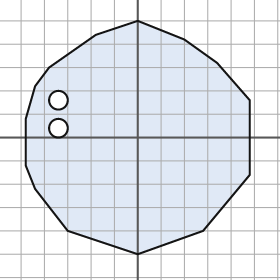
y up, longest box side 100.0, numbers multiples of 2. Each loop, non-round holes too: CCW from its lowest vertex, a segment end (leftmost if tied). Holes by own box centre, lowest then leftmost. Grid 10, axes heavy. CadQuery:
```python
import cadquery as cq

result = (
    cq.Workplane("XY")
    .moveTo(0.0, -50.0)
    .lineTo(28.0, -40.0)
    .lineTo(48.0, -16.0)
    .lineTo(48.0, 16.0)
    .lineTo(34.0, 32.0)
    .lineTo(20.0, 42.0)
    .lineTo(0.0, 50.0)
    .lineTo(-18.0, 44.0)
    .lineTo(-38.0, 30.0)
    .lineTo(-44.0, 22.0)
    .lineTo(-48.0, 8.0)
    .lineTo(-48.0, -12.0)
    .lineTo(-44.0, -22.0)
    .lineTo(-30.0, -40.0)
    .close()
    .moveTo(-34.0, 4.0)
    .circle(4.0)
    .moveTo(-34.0, 16.0)
    .circle(4.0)
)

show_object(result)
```